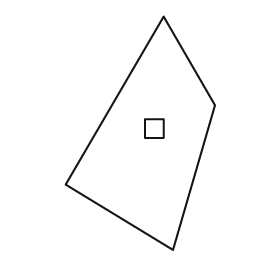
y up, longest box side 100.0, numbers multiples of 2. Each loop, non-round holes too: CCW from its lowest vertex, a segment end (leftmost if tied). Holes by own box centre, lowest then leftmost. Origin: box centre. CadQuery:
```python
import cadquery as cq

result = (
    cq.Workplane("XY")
    .moveTo(14.0, -50.0)
    .lineTo(32.0, 12.0)
    .lineTo(10.0, 50.0)
    .lineTo(-32.0, -22.0)
    .close()
    .moveTo(2.0, -2.0)
    .lineTo(10.0, -2.0)
    .lineTo(10.0, 6.0)
    .lineTo(2.0, 6.0)
    .close()
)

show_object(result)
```